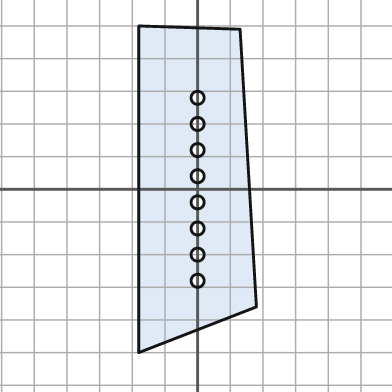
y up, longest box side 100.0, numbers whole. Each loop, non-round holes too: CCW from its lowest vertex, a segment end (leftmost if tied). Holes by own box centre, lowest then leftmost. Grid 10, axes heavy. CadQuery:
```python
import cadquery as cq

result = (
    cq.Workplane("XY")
    .moveTo(-18.0, -50.0)
    .lineTo(18.0, -36.0)
    .lineTo(13.0, 49.0)
    .lineTo(-18.0, 50.0)
    .close()
    .moveTo(0.0, -28.0)
    .circle(2.0)
    .moveTo(0.0, -20.0)
    .circle(2.0)
    .moveTo(0.0, -12.0)
    .circle(2.0)
    .moveTo(0.0, -4.0)
    .circle(2.0)
    .moveTo(0.0, 4.0)
    .circle(2.0)
    .moveTo(0.0, 12.0)
    .circle(2.0)
    .moveTo(0.0, 20.0)
    .circle(2.0)
    .moveTo(0.0, 28.0)
    .circle(2.0)
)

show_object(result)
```